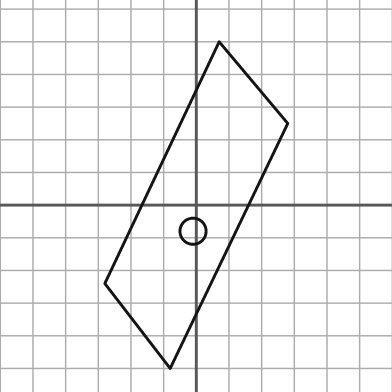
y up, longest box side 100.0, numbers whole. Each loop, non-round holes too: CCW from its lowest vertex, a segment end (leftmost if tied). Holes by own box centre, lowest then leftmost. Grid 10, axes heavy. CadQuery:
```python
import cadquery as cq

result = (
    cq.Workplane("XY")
    .moveTo(-8.0, -50.0)
    .lineTo(28.0, 25.0)
    .lineTo(7.0, 50.0)
    .lineTo(-28.0, -24.0)
    .close()
    .moveTo(-1.0, -8.0)
    .circle(4.0)
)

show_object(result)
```